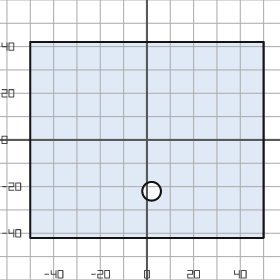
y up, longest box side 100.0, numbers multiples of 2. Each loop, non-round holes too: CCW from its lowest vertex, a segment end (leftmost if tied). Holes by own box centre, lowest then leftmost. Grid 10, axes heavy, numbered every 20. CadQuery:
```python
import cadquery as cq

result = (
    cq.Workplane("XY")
    .moveTo(-50.0, -42.0)
    .lineTo(50.0, -42.0)
    .lineTo(50.0, 42.0)
    .lineTo(-50.0, 42.0)
    .close()
    .moveTo(2.0, -22.0)
    .circle(4.0)
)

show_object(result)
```